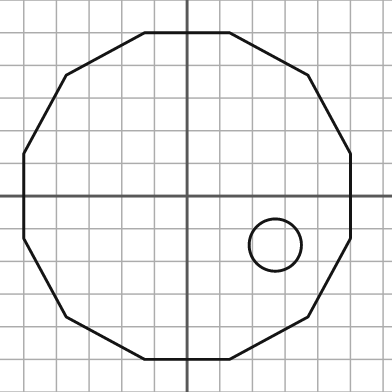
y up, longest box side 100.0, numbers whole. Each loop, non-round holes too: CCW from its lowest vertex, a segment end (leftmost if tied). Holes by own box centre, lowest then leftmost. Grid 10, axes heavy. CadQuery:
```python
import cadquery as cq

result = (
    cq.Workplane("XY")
    .moveTo(-13.0, -50.0)
    .lineTo(13.0, -50.0)
    .lineTo(37.0, -37.0)
    .lineTo(50.0, -13.0)
    .lineTo(50.0, 13.0)
    .lineTo(37.0, 37.0)
    .lineTo(13.0, 50.0)
    .lineTo(-13.0, 50.0)
    .lineTo(-37.0, 37.0)
    .lineTo(-50.0, 13.0)
    .lineTo(-50.0, -13.0)
    .lineTo(-37.0, -37.0)
    .close()
    .moveTo(27.0, -15.0)
    .circle(8.0)
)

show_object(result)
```